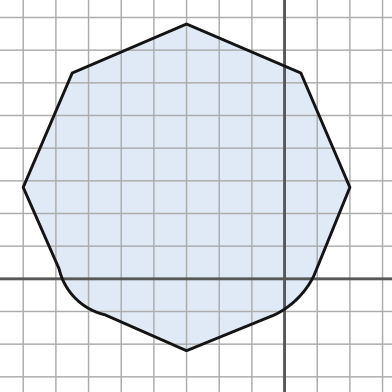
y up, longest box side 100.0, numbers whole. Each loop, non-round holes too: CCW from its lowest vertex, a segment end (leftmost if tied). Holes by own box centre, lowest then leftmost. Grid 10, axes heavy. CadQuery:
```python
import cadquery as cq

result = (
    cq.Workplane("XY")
    .moveTo(-30.0, -22.0)
    .lineTo(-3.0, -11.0)
    .threePointArc((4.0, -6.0), (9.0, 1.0))
    .lineTo(20.0, 28.0)
    .lineTo(5.0, 63.0)
    .lineTo(-30.0, 78.0)
    .lineTo(-65.0, 63.0)
    .lineTo(-80.0, 28.0)
    .lineTo(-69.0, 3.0)
    .threePointArc((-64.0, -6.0), (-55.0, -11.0))
    .close()
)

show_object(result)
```